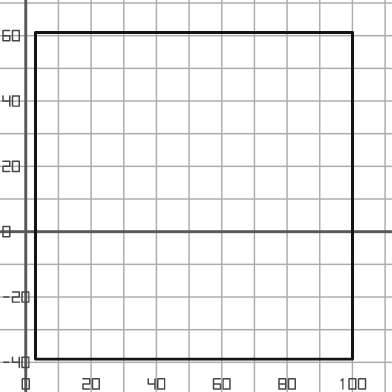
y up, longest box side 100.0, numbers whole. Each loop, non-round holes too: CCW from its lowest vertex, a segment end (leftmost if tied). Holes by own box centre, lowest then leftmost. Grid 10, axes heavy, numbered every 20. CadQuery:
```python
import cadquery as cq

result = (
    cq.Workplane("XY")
    .moveTo(3.0, -39.0)
    .lineTo(100.0, -39.0)
    .lineTo(100.0, 61.0)
    .lineTo(3.0, 61.0)
    .close()
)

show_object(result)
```